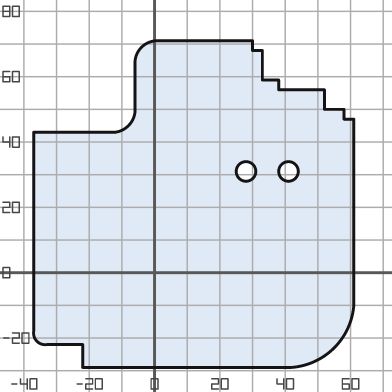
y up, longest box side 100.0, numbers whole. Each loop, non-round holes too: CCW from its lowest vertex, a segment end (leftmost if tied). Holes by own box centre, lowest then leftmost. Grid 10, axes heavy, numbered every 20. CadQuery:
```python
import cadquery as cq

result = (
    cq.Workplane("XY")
    .moveTo(-22.0, -29.0)
    .lineTo(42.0, -29.0)
    .threePointArc((55.0, -23.0), (61.0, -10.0))
    .lineTo(61.0, 47.0)
    .lineTo(58.0, 47.0)
    .lineTo(58.0, 50.0)
    .lineTo(52.0, 50.0)
    .lineTo(52.0, 56.0)
    .lineTo(38.0, 56.0)
    .lineTo(38.0, 59.0)
    .lineTo(33.0, 59.0)
    .lineTo(33.0, 68.0)
    .lineTo(30.0, 68.0)
    .lineTo(30.0, 71.0)
    .lineTo(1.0, 71.0)
    .threePointArc((-4.0, 69.0), (-6.0, 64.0))
    .lineTo(-6.0, 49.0)
    .threePointArc((-8.0, 45.0), (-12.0, 43.0))
    .lineTo(-37.0, 43.0)
    .lineTo(-37.0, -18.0)
    .threePointArc((-36.0, -21.0), (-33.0, -22.0))
    .lineTo(-22.0, -22.0)
    .close()
    .moveTo(28.0, 31.0)
    .circle(3.0)
    .moveTo(41.0, 31.0)
    .circle(3.0)
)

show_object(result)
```